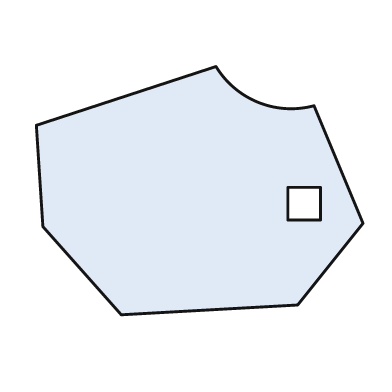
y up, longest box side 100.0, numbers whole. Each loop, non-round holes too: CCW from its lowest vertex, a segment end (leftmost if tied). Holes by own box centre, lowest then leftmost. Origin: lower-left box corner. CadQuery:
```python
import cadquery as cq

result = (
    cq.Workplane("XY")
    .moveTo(26.0, 0.0)
    .lineTo(80.0, 3.0)
    .lineTo(100.0, 28.0)
    .lineTo(85.0, 64.0)
    .threePointArc((68.0, 65.0), (55.0, 76.0))
    .lineTo(0.0, 58.0)
    .lineTo(2.0, 27.0)
    .close()
    .moveTo(77.0, 29.0)
    .lineTo(87.0, 29.0)
    .lineTo(87.0, 39.0)
    .lineTo(77.0, 39.0)
    .close()
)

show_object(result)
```